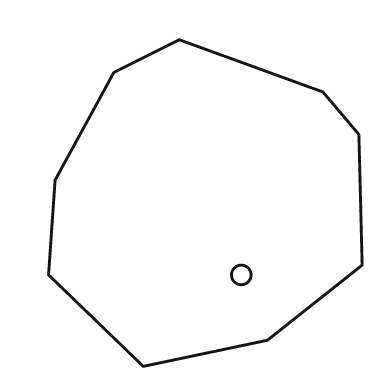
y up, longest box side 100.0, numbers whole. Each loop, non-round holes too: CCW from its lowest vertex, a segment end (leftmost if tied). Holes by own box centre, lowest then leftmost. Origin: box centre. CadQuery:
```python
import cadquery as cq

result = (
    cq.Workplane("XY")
    .moveTo(-19.0, -50.0)
    .lineTo(19.0, -42.0)
    .lineTo(48.0, -19.0)
    .lineTo(47.0, 21.0)
    .lineTo(36.0, 34.0)
    .lineTo(-8.0, 50.0)
    .lineTo(-28.0, 40.0)
    .lineTo(-46.0, 7.0)
    .lineTo(-48.0, -22.0)
    .close()
    .moveTo(11.0, -22.0)
    .circle(3.0)
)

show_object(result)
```